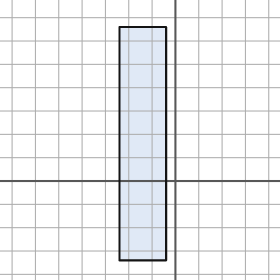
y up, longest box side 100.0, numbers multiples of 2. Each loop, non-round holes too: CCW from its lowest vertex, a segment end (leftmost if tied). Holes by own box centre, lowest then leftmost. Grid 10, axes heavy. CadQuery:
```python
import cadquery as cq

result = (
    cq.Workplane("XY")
    .moveTo(-24.0, -34.0)
    .lineTo(-4.0, -34.0)
    .lineTo(-4.0, 66.0)
    .lineTo(-24.0, 66.0)
    .close()
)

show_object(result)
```